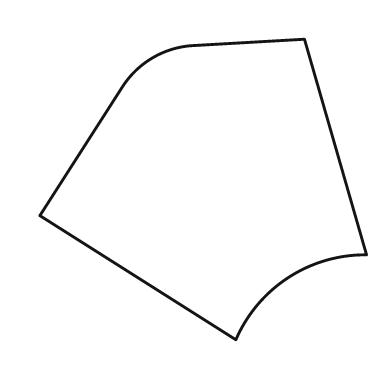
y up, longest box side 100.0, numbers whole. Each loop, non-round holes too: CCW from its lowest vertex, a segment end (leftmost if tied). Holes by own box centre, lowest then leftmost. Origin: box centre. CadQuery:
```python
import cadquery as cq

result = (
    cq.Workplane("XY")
    .moveTo(10.0, -46.0)
    .threePointArc((26.0, -27.0), (50.0, -20.0))
    .lineTo(31.0, 46.0)
    .lineTo(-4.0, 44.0)
    .threePointArc((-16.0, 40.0), (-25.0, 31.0))
    .lineTo(-50.0, -8.0)
    .close()
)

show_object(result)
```